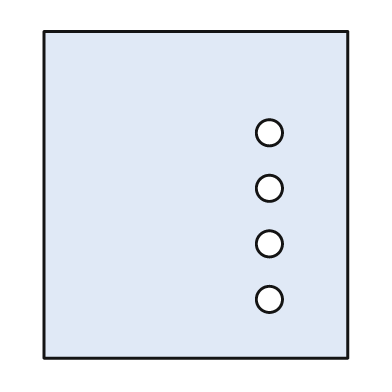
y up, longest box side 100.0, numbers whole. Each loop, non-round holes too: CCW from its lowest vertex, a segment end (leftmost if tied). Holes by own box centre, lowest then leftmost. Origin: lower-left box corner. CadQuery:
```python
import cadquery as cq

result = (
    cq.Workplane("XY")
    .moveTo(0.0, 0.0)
    .lineTo(93.0, 0.0)
    .lineTo(93.0, 100.0)
    .lineTo(0.0, 100.0)
    .close()
    .moveTo(69.0, 18.0)
    .circle(4.0)
    .moveTo(69.0, 35.0)
    .circle(4.0)
    .moveTo(69.0, 52.0)
    .circle(4.0)
    .moveTo(69.0, 69.0)
    .circle(4.0)
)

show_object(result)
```